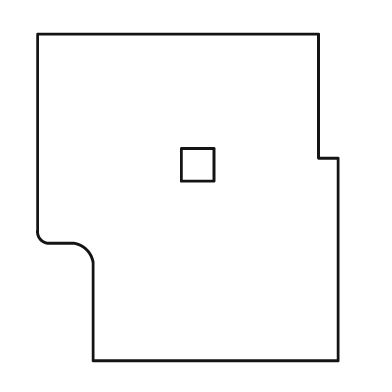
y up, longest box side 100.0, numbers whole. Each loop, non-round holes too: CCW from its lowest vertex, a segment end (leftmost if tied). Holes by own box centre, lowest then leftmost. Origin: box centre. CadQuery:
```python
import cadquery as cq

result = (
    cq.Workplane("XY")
    .moveTo(-29.0, -50.0)
    .lineTo(46.0, -50.0)
    .lineTo(46.0, 12.0)
    .lineTo(40.0, 12.0)
    .lineTo(40.0, 50.0)
    .lineTo(-46.0, 50.0)
    .lineTo(-46.0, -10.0)
    .threePointArc((-45.0, -13.0), (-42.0, -14.0))
    .lineTo(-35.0, -14.0)
    .threePointArc((-31.0, -16.0), (-29.0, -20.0))
    .close()
    .moveTo(-2.0, 5.0)
    .lineTo(8.0, 5.0)
    .lineTo(8.0, 15.0)
    .lineTo(-2.0, 15.0)
    .close()
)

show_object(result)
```